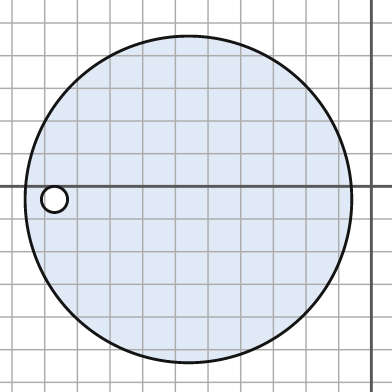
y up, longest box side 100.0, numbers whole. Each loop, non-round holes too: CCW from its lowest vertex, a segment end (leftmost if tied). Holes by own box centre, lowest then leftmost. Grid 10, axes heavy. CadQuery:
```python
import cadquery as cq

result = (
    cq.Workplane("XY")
    .moveTo(-56.0, -4.0)
    .circle(50.0)
    .moveTo(-97.0, -4.0)
    .circle(4.0)
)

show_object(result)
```